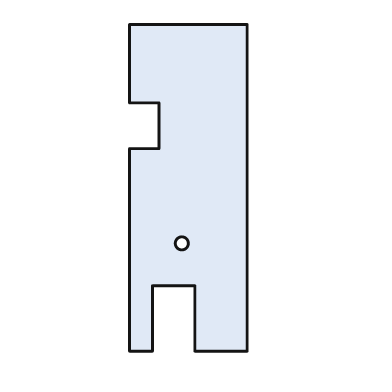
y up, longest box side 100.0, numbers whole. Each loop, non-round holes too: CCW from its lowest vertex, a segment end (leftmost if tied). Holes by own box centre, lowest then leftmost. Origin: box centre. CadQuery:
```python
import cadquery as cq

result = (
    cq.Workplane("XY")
    .moveTo(-18.0, -50.0)
    .lineTo(-11.0, -50.0)
    .lineTo(-11.0, -30.0)
    .lineTo(2.0, -30.0)
    .lineTo(2.0, -50.0)
    .lineTo(18.0, -50.0)
    .lineTo(18.0, 50.0)
    .lineTo(-18.0, 50.0)
    .lineTo(-18.0, 26.0)
    .lineTo(-9.0, 26.0)
    .lineTo(-9.0, 12.0)
    .lineTo(-18.0, 12.0)
    .close()
    .moveTo(-2.0, -17.0)
    .circle(2.0)
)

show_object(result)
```